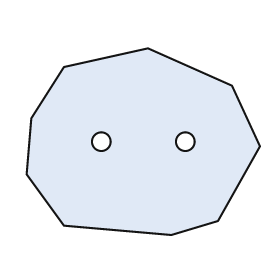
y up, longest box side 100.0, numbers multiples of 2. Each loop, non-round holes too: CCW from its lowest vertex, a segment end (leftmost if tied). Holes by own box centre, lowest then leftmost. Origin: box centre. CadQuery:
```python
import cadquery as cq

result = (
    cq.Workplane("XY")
    .moveTo(12.0, -40.0)
    .lineTo(32.0, -34.0)
    .lineTo(50.0, -2.0)
    .lineTo(38.0, 24.0)
    .lineTo(2.0, 40.0)
    .lineTo(-34.0, 32.0)
    .lineTo(-48.0, 10.0)
    .lineTo(-50.0, -14.0)
    .lineTo(-34.0, -36.0)
    .close()
    .moveTo(-18.0, 0.0)
    .circle(4.0)
    .moveTo(18.0, 0.0)
    .circle(4.0)
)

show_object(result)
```